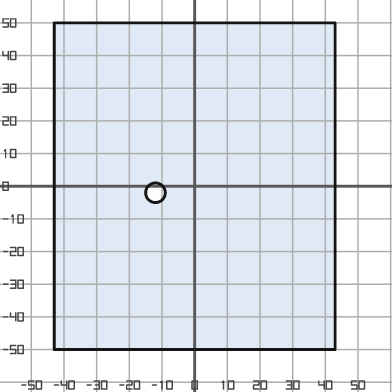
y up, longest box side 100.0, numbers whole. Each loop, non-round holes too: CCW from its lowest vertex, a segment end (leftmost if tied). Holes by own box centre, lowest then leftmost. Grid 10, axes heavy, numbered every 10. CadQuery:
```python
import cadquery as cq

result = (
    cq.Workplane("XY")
    .moveTo(-43.0, -50.0)
    .lineTo(43.0, -50.0)
    .lineTo(43.0, 50.0)
    .lineTo(-43.0, 50.0)
    .close()
    .moveTo(-12.0, -2.0)
    .circle(3.0)
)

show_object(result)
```